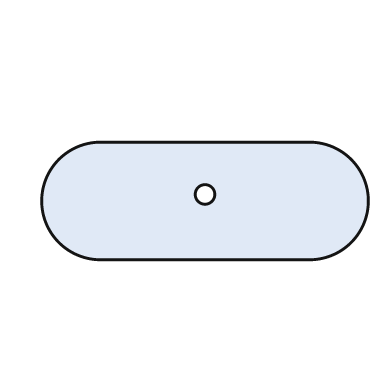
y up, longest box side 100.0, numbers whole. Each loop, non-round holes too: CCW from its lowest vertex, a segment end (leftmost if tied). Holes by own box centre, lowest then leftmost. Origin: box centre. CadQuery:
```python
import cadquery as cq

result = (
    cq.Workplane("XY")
    .moveTo(-32.0, -18.0)
    .lineTo(32.0, -18.0)
    .threePointArc((50.0, 0.0), (32.0, 18.0))
    .lineTo(-32.0, 18.0)
    .threePointArc((-50.0, 0.0), (-32.0, -18.0))
    .close()
    .moveTo(0.0, 2.0)
    .circle(3.0)
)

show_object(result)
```